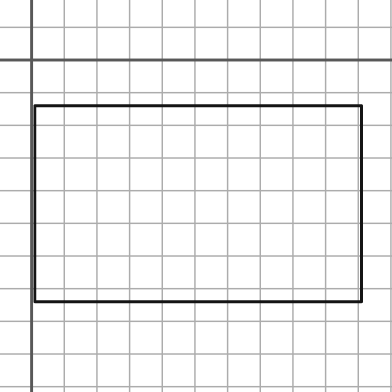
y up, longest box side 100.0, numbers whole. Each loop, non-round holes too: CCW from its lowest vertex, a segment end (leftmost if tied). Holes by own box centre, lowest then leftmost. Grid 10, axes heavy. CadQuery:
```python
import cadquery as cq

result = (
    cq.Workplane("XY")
    .moveTo(1.0, -74.0)
    .lineTo(101.0, -74.0)
    .lineTo(101.0, -14.0)
    .lineTo(1.0, -14.0)
    .close()
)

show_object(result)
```